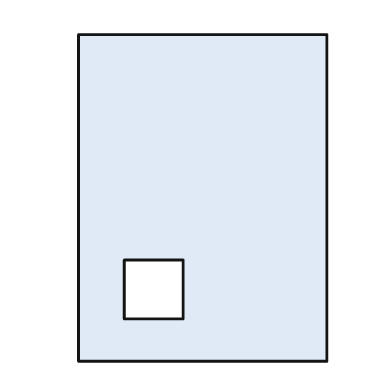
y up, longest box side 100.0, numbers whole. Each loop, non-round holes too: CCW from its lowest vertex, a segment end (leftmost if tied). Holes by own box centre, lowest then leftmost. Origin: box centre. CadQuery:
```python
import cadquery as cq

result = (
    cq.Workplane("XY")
    .moveTo(-38.0, -50.0)
    .lineTo(38.0, -50.0)
    .lineTo(38.0, 50.0)
    .lineTo(-38.0, 50.0)
    .close()
    .moveTo(-24.0, -37.0)
    .lineTo(-6.0, -37.0)
    .lineTo(-6.0, -19.0)
    .lineTo(-24.0, -19.0)
    .close()
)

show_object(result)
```